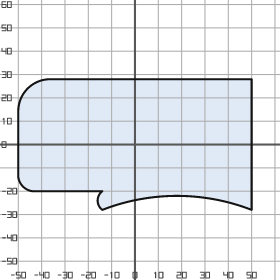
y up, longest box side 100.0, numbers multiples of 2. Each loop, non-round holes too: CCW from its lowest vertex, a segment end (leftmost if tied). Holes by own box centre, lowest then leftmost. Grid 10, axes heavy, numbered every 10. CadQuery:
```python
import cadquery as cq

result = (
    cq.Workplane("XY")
    .moveTo(-14.0, -28.0)
    .threePointArc((18.0, -22.0), (50.0, -28.0))
    .lineTo(50.0, 28.0)
    .lineTo(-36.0, 28.0)
    .threePointArc((-46.0, 24.0), (-50.0, 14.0))
    .lineTo(-50.0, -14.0)
    .threePointArc((-48.0, -18.0), (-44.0, -20.0))
    .lineTo(-14.0, -20.0)
    .threePointArc((-16.0, -24.0), (-14.0, -28.0))
    .close()
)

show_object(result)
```